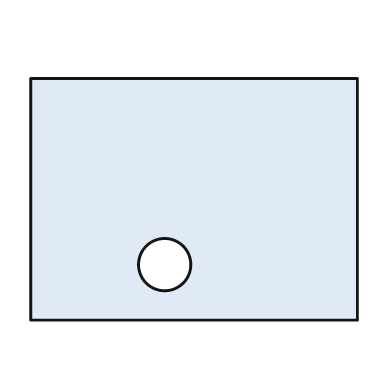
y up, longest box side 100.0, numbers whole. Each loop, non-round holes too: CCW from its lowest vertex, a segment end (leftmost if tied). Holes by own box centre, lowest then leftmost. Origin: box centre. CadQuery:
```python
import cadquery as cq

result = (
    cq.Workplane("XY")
    .moveTo(-50.0, -37.0)
    .lineTo(50.0, -37.0)
    .lineTo(50.0, 37.0)
    .lineTo(-50.0, 37.0)
    .close()
    .moveTo(-9.0, -20.0)
    .circle(8.0)
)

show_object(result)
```